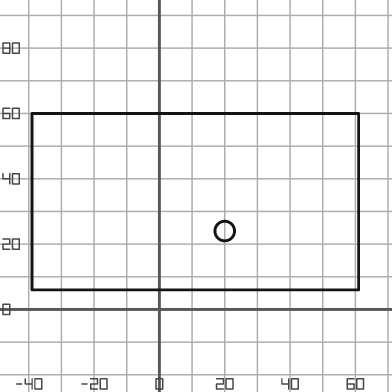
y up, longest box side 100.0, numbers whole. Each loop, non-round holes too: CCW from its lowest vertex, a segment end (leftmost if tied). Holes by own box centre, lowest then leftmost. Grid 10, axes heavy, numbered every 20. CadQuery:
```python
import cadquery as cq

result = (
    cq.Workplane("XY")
    .moveTo(-39.0, 6.0)
    .lineTo(61.0, 6.0)
    .lineTo(61.0, 60.0)
    .lineTo(-39.0, 60.0)
    .close()
    .moveTo(20.0, 24.0)
    .circle(3.0)
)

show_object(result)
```